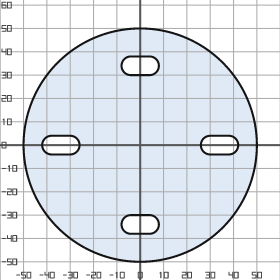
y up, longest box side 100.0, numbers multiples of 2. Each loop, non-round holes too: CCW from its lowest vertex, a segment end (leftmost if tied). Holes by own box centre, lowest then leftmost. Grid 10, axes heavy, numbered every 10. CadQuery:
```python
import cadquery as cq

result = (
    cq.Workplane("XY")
    .moveTo(0.0, 0.0)
    .circle(50.0)
    .moveTo(-4.0, -38.0)
    .lineTo(4.0, -38.0)
    .threePointArc((8.0, -34.0), (4.0, -30.0))
    .lineTo(-4.0, -30.0)
    .threePointArc((-8.0, -34.0), (-4.0, -38.0))
    .close()
    .moveTo(-38.0, -4.0)
    .lineTo(-30.0, -4.0)
    .threePointArc((-26.0, 0.0), (-30.0, 4.0))
    .lineTo(-38.0, 4.0)
    .threePointArc((-42.0, 0.0), (-38.0, -4.0))
    .close()
    .moveTo(30.0, -4.0)
    .lineTo(38.0, -4.0)
    .threePointArc((42.0, 0.0), (38.0, 4.0))
    .lineTo(30.0, 4.0)
    .threePointArc((26.0, 0.0), (30.0, -4.0))
    .close()
    .moveTo(-4.0, 30.0)
    .lineTo(4.0, 30.0)
    .threePointArc((8.0, 34.0), (4.0, 38.0))
    .lineTo(-4.0, 38.0)
    .threePointArc((-8.0, 34.0), (-4.0, 30.0))
    .close()
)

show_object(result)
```